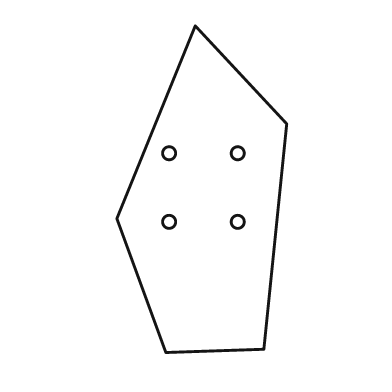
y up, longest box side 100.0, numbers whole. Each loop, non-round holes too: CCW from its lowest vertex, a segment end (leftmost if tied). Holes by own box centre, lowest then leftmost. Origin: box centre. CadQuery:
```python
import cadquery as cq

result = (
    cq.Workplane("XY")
    .moveTo(-11.0, -50.0)
    .lineTo(19.0, -49.0)
    .lineTo(26.0, 20.0)
    .lineTo(-2.0, 50.0)
    .lineTo(-26.0, -9.0)
    .close()
    .moveTo(-10.0, -10.0)
    .circle(2.0)
    .moveTo(11.0, -10.0)
    .circle(2.0)
    .moveTo(-10.0, 11.0)
    .circle(2.0)
    .moveTo(11.0, 11.0)
    .circle(2.0)
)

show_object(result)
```